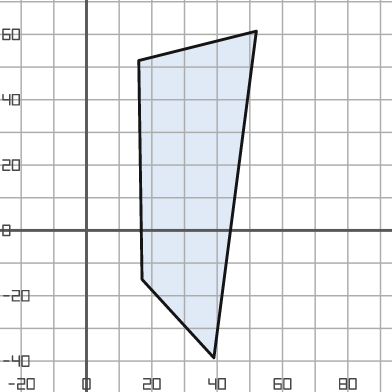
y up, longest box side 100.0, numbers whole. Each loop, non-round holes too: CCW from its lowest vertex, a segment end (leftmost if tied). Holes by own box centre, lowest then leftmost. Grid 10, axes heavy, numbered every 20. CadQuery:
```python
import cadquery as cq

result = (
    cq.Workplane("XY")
    .moveTo(39.0, -39.0)
    .lineTo(52.0, 61.0)
    .lineTo(16.0, 52.0)
    .lineTo(17.0, -15.0)
    .close()
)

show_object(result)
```